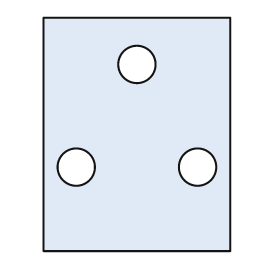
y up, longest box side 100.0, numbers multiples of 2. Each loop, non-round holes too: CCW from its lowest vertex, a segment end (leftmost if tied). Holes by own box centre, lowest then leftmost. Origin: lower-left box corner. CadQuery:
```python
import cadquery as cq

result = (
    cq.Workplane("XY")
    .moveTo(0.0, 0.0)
    .lineTo(80.0, 0.0)
    .lineTo(80.0, 100.0)
    .lineTo(0.0, 100.0)
    .close()
    .moveTo(14.0, 36.0)
    .circle(8.0)
    .moveTo(66.0, 36.0)
    .circle(8.0)
    .moveTo(40.0, 80.0)
    .circle(8.0)
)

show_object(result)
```